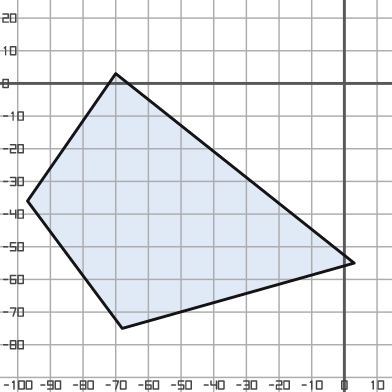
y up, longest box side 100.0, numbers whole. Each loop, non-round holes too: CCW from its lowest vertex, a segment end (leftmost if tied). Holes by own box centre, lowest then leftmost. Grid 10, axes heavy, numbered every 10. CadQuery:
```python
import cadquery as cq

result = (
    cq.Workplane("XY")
    .moveTo(-68.0, -75.0)
    .lineTo(3.0, -55.0)
    .lineTo(-70.0, 3.0)
    .lineTo(-97.0, -36.0)
    .close()
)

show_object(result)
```